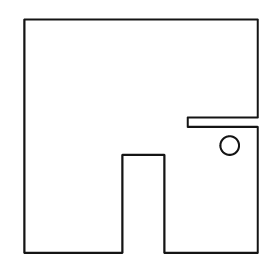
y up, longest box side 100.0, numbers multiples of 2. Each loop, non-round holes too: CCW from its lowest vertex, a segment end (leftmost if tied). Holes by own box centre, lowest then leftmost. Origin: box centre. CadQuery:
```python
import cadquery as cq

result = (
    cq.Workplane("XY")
    .moveTo(-50.0, -50.0)
    .lineTo(-8.0, -50.0)
    .lineTo(-8.0, -8.0)
    .lineTo(10.0, -8.0)
    .lineTo(10.0, -50.0)
    .lineTo(50.0, -50.0)
    .lineTo(50.0, 4.0)
    .lineTo(20.0, 4.0)
    .lineTo(20.0, 8.0)
    .lineTo(50.0, 8.0)
    .lineTo(50.0, 50.0)
    .lineTo(-50.0, 50.0)
    .close()
    .moveTo(38.0, -4.0)
    .circle(4.0)
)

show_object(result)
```